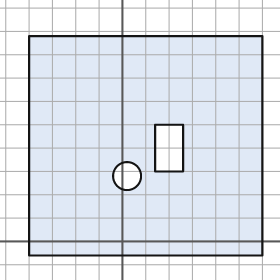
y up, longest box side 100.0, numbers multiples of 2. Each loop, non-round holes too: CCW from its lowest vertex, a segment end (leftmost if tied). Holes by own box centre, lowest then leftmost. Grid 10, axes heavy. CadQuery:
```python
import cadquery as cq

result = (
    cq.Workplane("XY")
    .moveTo(-40.0, -6.0)
    .lineTo(60.0, -6.0)
    .lineTo(60.0, 88.0)
    .lineTo(-40.0, 88.0)
    .close()
    .moveTo(2.0, 28.0)
    .circle(6.0)
    .moveTo(14.0, 30.0)
    .lineTo(26.0, 30.0)
    .lineTo(26.0, 50.0)
    .lineTo(14.0, 50.0)
    .close()
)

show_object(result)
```